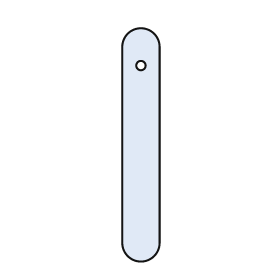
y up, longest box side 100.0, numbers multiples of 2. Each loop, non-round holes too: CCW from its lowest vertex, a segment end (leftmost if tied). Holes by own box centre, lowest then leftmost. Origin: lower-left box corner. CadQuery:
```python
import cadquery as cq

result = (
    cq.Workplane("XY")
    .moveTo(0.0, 8.0)
    .threePointArc((8.0, 0.0), (16.0, 8.0))
    .lineTo(16.0, 92.0)
    .threePointArc((8.0, 100.0), (0.0, 92.0))
    .close()
    .moveTo(8.0, 84.0)
    .circle(2.0)
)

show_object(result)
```